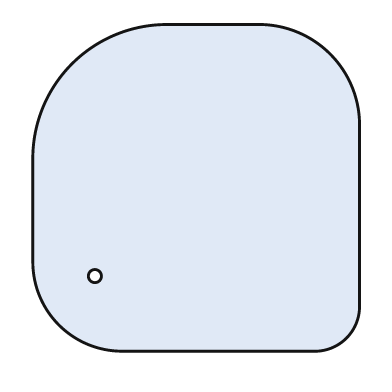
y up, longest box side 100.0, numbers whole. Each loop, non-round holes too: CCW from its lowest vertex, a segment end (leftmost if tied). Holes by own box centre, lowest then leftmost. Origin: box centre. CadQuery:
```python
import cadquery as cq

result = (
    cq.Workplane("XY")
    .moveTo(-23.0, -50.0)
    .lineTo(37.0, -50.0)
    .threePointArc((46.0, -46.0), (50.0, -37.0))
    .lineTo(50.0, 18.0)
    .threePointArc((41.0, 41.0), (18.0, 50.0))
    .lineTo(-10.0, 50.0)
    .threePointArc((-38.0, 38.0), (-50.0, 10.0))
    .lineTo(-50.0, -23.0)
    .threePointArc((-42.0, -42.0), (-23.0, -50.0))
    .close()
    .moveTo(-31.0, -27.0)
    .circle(2.0)
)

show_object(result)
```